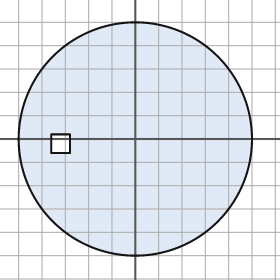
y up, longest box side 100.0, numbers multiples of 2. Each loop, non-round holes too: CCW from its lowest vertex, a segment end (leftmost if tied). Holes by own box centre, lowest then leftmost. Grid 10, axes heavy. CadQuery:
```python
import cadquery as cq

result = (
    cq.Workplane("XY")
    .moveTo(0.0, 0.0)
    .circle(50.0)
    .moveTo(-36.0, -6.0)
    .lineTo(-28.0, -6.0)
    .lineTo(-28.0, 2.0)
    .lineTo(-36.0, 2.0)
    .close()
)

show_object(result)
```